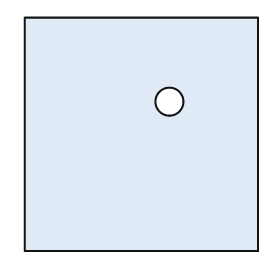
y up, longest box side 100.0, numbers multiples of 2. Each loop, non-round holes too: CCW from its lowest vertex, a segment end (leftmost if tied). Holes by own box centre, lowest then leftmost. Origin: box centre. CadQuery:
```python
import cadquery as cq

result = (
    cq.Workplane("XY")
    .moveTo(-50.0, -50.0)
    .lineTo(50.0, -50.0)
    .lineTo(50.0, 50.0)
    .lineTo(-50.0, 50.0)
    .close()
    .moveTo(12.0, 14.0)
    .circle(6.0)
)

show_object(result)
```